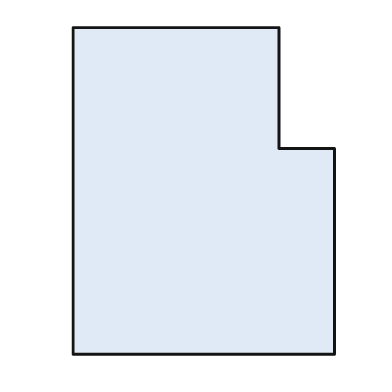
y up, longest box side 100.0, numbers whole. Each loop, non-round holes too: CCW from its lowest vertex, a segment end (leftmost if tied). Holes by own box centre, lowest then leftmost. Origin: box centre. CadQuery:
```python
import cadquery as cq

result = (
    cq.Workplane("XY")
    .moveTo(-40.0, -50.0)
    .lineTo(40.0, -50.0)
    .lineTo(40.0, 13.0)
    .lineTo(23.0, 13.0)
    .lineTo(23.0, 50.0)
    .lineTo(-40.0, 50.0)
    .close()
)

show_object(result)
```